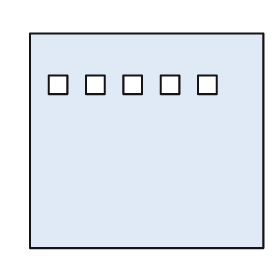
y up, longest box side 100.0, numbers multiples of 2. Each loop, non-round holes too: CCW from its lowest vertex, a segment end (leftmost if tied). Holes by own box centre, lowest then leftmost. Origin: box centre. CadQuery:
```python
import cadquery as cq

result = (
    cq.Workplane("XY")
    .moveTo(-50.0, -46.0)
    .lineTo(50.0, -46.0)
    .lineTo(50.0, 46.0)
    .lineTo(-50.0, 46.0)
    .close()
    .moveTo(-42.0, 20.0)
    .lineTo(-34.0, 20.0)
    .lineTo(-34.0, 28.0)
    .lineTo(-42.0, 28.0)
    .close()
    .moveTo(-26.0, 20.0)
    .lineTo(-18.0, 20.0)
    .lineTo(-18.0, 28.0)
    .lineTo(-26.0, 28.0)
    .close()
    .moveTo(-10.0, 20.0)
    .lineTo(-2.0, 20.0)
    .lineTo(-2.0, 28.0)
    .lineTo(-10.0, 28.0)
    .close()
    .moveTo(6.0, 20.0)
    .lineTo(14.0, 20.0)
    .lineTo(14.0, 28.0)
    .lineTo(6.0, 28.0)
    .close()
    .moveTo(22.0, 20.0)
    .lineTo(30.0, 20.0)
    .lineTo(30.0, 28.0)
    .lineTo(22.0, 28.0)
    .close()
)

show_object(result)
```